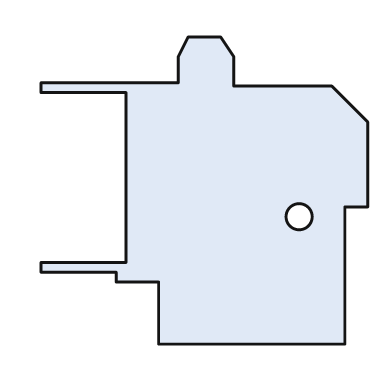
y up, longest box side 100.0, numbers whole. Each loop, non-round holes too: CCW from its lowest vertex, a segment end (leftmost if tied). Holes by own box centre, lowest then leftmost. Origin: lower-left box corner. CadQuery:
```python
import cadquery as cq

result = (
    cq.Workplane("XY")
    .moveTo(36.0, 0.0)
    .lineTo(93.0, 0.0)
    .lineTo(93.0, 42.0)
    .lineTo(100.0, 42.0)
    .lineTo(100.0, 68.0)
    .lineTo(89.0, 79.0)
    .lineTo(59.0, 79.0)
    .lineTo(59.0, 88.0)
    .lineTo(55.0, 94.0)
    .lineTo(45.0, 94.0)
    .lineTo(42.0, 88.0)
    .lineTo(42.0, 80.0)
    .lineTo(0.0, 80.0)
    .lineTo(0.0, 77.0)
    .lineTo(26.0, 77.0)
    .lineTo(26.0, 25.0)
    .lineTo(0.0, 25.0)
    .lineTo(0.0, 22.0)
    .lineTo(23.0, 22.0)
    .lineTo(23.0, 19.0)
    .lineTo(36.0, 19.0)
    .close()
    .moveTo(79.0, 39.0)
    .circle(4.0)
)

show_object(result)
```